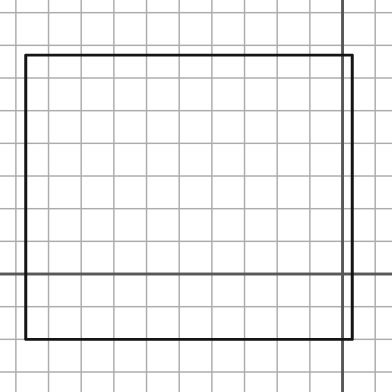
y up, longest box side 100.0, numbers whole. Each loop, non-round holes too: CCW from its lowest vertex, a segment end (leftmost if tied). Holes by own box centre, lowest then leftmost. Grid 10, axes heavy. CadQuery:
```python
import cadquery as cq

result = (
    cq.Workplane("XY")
    .moveTo(-97.0, -20.0)
    .lineTo(3.0, -20.0)
    .lineTo(3.0, 67.0)
    .lineTo(-97.0, 67.0)
    .close()
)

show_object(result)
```